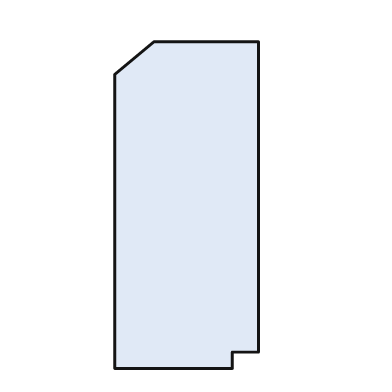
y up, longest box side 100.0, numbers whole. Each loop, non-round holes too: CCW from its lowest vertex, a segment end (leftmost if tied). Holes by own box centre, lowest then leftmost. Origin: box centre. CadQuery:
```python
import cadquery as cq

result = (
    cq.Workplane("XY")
    .moveTo(-22.0, -50.0)
    .lineTo(14.0, -50.0)
    .lineTo(14.0, -45.0)
    .lineTo(22.0, -45.0)
    .lineTo(22.0, 50.0)
    .lineTo(-10.0, 50.0)
    .lineTo(-22.0, 40.0)
    .close()
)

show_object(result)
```